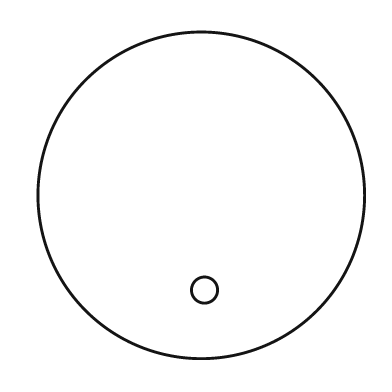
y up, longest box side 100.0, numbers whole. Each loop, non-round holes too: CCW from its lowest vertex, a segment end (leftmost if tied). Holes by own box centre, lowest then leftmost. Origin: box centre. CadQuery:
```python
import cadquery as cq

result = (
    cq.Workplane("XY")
    .moveTo(0.0, 0.0)
    .circle(50.0)
    .moveTo(1.0, -29.0)
    .circle(4.0)
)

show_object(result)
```